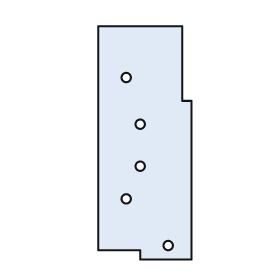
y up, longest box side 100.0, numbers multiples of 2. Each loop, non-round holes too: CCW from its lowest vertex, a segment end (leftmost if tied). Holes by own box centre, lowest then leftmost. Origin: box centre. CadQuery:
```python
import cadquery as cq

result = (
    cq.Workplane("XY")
    .moveTo(-2.0, -50.0)
    .lineTo(20.0, -50.0)
    .lineTo(20.0, 18.0)
    .lineTo(16.0, 18.0)
    .lineTo(16.0, 50.0)
    .lineTo(-20.0, 50.0)
    .lineTo(-20.0, -46.0)
    .lineTo(-2.0, -46.0)
    .close()
    .moveTo(10.0, -44.0)
    .circle(2.0)
    .moveTo(-8.0, -24.0)
    .circle(2.0)
    .moveTo(-2.0, -10.0)
    .circle(2.0)
    .moveTo(-2.0, 8.0)
    .circle(2.0)
    .moveTo(-8.0, 28.0)
    .circle(2.0)
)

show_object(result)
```